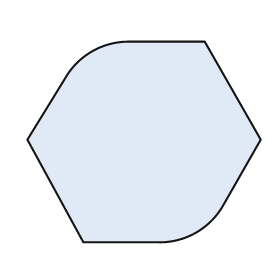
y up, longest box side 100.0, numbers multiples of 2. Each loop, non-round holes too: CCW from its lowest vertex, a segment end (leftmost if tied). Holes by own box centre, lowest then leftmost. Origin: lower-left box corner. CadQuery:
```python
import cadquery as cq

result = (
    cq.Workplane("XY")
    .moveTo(24.0, 0.0)
    .lineTo(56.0, 0.0)
    .threePointArc((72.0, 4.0), (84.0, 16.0))
    .lineTo(100.0, 44.0)
    .lineTo(76.0, 86.0)
    .lineTo(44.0, 86.0)
    .threePointArc((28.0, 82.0), (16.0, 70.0))
    .lineTo(0.0, 44.0)
    .close()
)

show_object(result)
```